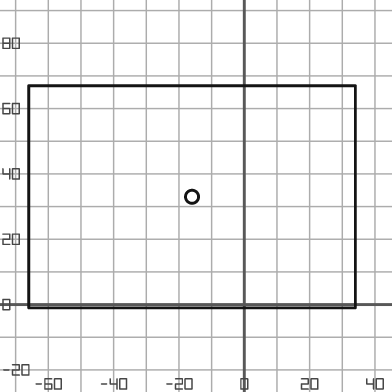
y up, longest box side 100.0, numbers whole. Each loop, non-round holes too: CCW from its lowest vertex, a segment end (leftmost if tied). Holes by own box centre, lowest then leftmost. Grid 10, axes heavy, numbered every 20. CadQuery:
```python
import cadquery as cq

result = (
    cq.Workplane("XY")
    .moveTo(-66.0, -1.0)
    .lineTo(34.0, -1.0)
    .lineTo(34.0, 67.0)
    .lineTo(-66.0, 67.0)
    .close()
    .moveTo(-16.0, 33.0)
    .circle(2.0)
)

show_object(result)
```